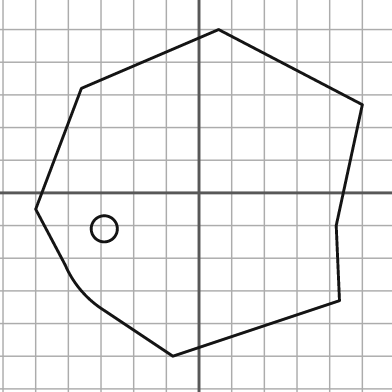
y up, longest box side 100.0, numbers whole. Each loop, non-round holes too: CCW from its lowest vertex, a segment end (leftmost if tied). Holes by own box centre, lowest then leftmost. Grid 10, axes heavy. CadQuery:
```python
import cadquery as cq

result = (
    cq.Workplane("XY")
    .moveTo(-8.0, -50.0)
    .lineTo(43.0, -33.0)
    .lineTo(42.0, -10.0)
    .lineTo(50.0, 27.0)
    .lineTo(6.0, 50.0)
    .lineTo(-36.0, 32.0)
    .lineTo(-50.0, -5.0)
    .lineTo(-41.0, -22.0)
    .threePointArc((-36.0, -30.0), (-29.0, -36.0))
    .close()
    .moveTo(-29.0, -11.0)
    .circle(4.0)
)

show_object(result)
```